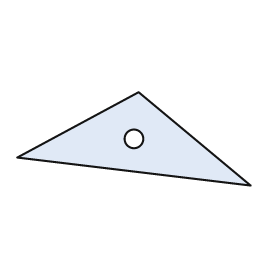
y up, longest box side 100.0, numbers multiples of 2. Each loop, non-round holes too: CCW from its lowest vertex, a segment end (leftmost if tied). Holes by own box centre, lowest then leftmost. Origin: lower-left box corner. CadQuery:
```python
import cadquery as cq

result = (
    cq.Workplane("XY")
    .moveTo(100.0, 0.0)
    .lineTo(52.0, 40.0)
    .lineTo(0.0, 12.0)
    .close()
    .moveTo(50.0, 20.0)
    .circle(4.0)
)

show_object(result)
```